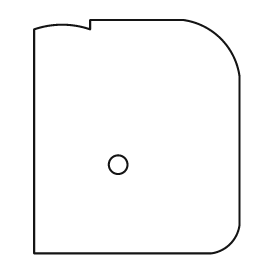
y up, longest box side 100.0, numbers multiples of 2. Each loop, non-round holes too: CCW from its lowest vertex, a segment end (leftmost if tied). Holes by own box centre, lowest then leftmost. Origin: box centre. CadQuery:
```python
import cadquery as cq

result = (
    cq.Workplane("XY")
    .moveTo(-44.0, -50.0)
    .lineTo(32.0, -50.0)
    .threePointArc((40.0, -46.0), (44.0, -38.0))
    .lineTo(44.0, 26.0)
    .threePointArc((36.0, 42.0), (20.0, 50.0))
    .lineTo(-20.0, 50.0)
    .lineTo(-20.0, 46.0)
    .threePointArc((-32.0, 48.0), (-44.0, 46.0))
    .close()
    .moveTo(-8.0, -12.0)
    .circle(4.0)
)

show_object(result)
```